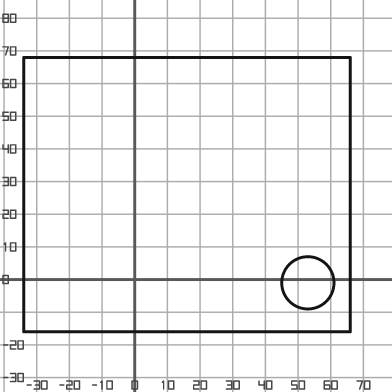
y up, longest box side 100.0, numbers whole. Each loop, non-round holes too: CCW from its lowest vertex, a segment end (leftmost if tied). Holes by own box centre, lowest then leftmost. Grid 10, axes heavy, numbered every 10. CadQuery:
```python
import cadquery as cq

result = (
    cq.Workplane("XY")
    .moveTo(-34.0, -16.0)
    .lineTo(66.0, -16.0)
    .lineTo(66.0, 68.0)
    .lineTo(-34.0, 68.0)
    .close()
    .moveTo(53.0, -1.0)
    .circle(8.0)
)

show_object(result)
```